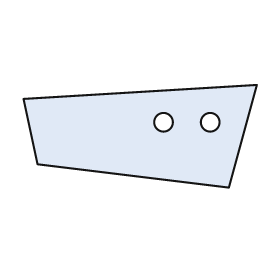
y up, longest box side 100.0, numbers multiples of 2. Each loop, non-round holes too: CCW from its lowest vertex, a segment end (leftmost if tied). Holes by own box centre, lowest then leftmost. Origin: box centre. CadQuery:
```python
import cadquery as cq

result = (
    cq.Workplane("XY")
    .moveTo(38.0, -22.0)
    .lineTo(50.0, 22.0)
    .lineTo(-50.0, 16.0)
    .lineTo(-44.0, -12.0)
    .close()
    .moveTo(10.0, 6.0)
    .circle(4.0)
    .moveTo(30.0, 6.0)
    .circle(4.0)
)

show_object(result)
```